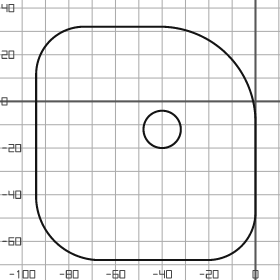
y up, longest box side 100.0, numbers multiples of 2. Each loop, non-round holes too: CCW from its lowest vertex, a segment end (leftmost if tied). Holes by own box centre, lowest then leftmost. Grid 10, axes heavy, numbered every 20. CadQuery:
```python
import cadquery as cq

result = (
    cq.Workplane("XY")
    .moveTo(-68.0, -68.0)
    .lineTo(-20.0, -68.0)
    .threePointArc((-6.0, -62.0), (0.0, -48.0))
    .lineTo(0.0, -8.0)
    .threePointArc((-12.0, 20.0), (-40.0, 32.0))
    .lineTo(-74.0, 32.0)
    .threePointArc((-88.0, 26.0), (-94.0, 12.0))
    .lineTo(-94.0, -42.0)
    .threePointArc((-86.0, -60.0), (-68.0, -68.0))
    .close()
    .moveTo(-40.0, -12.0)
    .circle(8.0)
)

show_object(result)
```